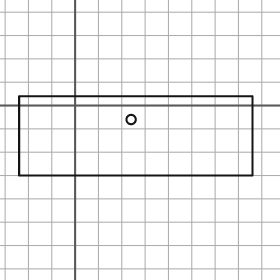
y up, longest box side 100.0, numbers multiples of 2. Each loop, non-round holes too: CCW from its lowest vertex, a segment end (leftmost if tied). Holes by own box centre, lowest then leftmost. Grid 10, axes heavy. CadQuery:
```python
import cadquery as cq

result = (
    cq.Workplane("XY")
    .moveTo(-24.0, -30.0)
    .lineTo(76.0, -30.0)
    .lineTo(76.0, 4.0)
    .lineTo(-24.0, 4.0)
    .close()
    .moveTo(24.0, -6.0)
    .circle(2.0)
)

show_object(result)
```